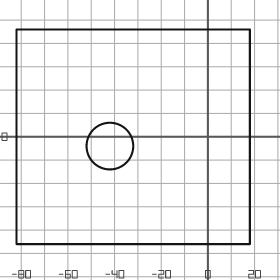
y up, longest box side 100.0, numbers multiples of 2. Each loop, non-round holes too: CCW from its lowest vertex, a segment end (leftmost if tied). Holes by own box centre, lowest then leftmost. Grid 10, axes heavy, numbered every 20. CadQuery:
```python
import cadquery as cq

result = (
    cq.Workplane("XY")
    .moveTo(-82.0, -46.0)
    .lineTo(18.0, -46.0)
    .lineTo(18.0, 46.0)
    .lineTo(-82.0, 46.0)
    .close()
    .moveTo(-42.0, -4.0)
    .circle(10.0)
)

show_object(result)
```